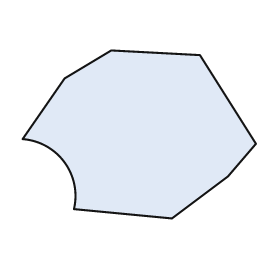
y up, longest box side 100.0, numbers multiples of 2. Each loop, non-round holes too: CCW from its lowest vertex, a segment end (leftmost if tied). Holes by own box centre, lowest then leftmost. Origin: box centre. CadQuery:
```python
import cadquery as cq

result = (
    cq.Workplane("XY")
    .moveTo(14.0, -36.0)
    .lineTo(38.0, -18.0)
    .lineTo(50.0, -4.0)
    .lineTo(26.0, 34.0)
    .lineTo(-12.0, 36.0)
    .lineTo(-32.0, 24.0)
    .lineTo(-50.0, -2.0)
    .threePointArc((-32.0, -12.0), (-28.0, -32.0))
    .close()
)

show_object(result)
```